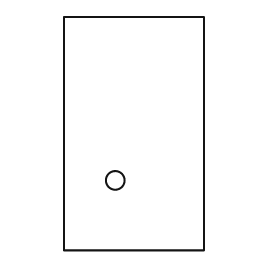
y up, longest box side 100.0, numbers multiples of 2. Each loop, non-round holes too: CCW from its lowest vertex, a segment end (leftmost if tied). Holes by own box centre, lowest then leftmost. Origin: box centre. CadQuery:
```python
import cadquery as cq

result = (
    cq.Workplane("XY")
    .moveTo(-30.0, -50.0)
    .lineTo(30.0, -50.0)
    .lineTo(30.0, 50.0)
    .lineTo(-30.0, 50.0)
    .close()
    .moveTo(-8.0, -20.0)
    .circle(4.0)
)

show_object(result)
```